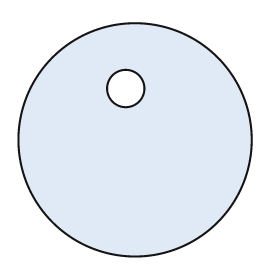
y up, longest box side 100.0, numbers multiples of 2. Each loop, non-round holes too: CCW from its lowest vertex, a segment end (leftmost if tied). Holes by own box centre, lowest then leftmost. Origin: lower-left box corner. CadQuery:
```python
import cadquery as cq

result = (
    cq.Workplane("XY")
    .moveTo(50.0, 50.0)
    .circle(50.0)
    .moveTo(46.0, 72.0)
    .circle(8.0)
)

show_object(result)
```